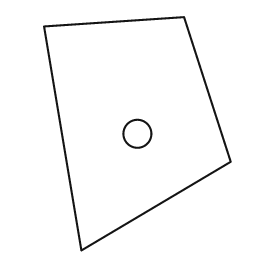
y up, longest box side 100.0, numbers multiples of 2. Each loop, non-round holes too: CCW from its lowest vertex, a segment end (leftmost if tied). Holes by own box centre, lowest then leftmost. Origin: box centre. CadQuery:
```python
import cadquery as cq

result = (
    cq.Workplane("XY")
    .moveTo(-24.0, -50.0)
    .lineTo(40.0, -12.0)
    .lineTo(20.0, 50.0)
    .lineTo(-40.0, 46.0)
    .close()
    .moveTo(0.0, 0.0)
    .circle(6.0)
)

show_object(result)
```